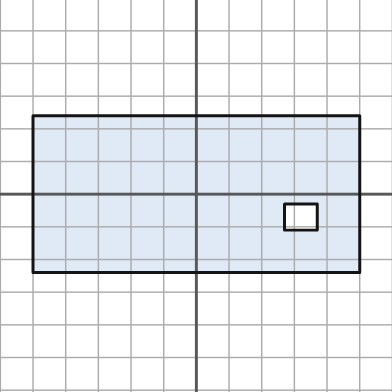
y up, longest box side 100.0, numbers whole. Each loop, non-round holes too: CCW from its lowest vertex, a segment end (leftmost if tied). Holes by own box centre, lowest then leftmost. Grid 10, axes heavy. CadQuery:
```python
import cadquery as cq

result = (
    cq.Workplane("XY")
    .moveTo(-50.0, -24.0)
    .lineTo(50.0, -24.0)
    .lineTo(50.0, 24.0)
    .lineTo(-50.0, 24.0)
    .close()
    .moveTo(27.0, -11.0)
    .lineTo(37.0, -11.0)
    .lineTo(37.0, -3.0)
    .lineTo(27.0, -3.0)
    .close()
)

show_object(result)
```